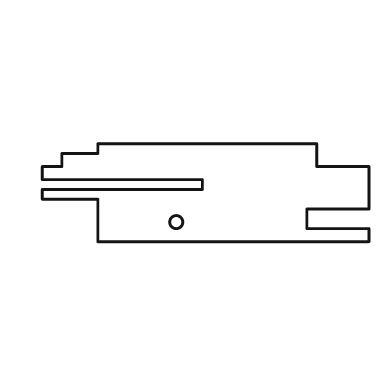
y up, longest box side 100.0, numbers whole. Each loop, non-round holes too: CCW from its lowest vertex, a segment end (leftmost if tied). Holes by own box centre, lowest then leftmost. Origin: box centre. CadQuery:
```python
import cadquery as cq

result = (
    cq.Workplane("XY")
    .moveTo(-33.0, -15.0)
    .lineTo(50.0, -15.0)
    .lineTo(50.0, -11.0)
    .lineTo(31.0, -11.0)
    .lineTo(31.0, -5.0)
    .lineTo(50.0, -5.0)
    .lineTo(50.0, 8.0)
    .lineTo(34.0, 8.0)
    .lineTo(34.0, 15.0)
    .lineTo(-33.0, 15.0)
    .lineTo(-33.0, 12.0)
    .lineTo(-44.0, 12.0)
    .lineTo(-44.0, 8.0)
    .lineTo(-50.0, 8.0)
    .lineTo(-50.0, 4.0)
    .lineTo(-1.0, 4.0)
    .lineTo(-1.0, 1.0)
    .lineTo(-50.0, 1.0)
    .lineTo(-50.0, -2.0)
    .lineTo(-33.0, -2.0)
    .close()
    .moveTo(-9.0, -9.0)
    .circle(2.0)
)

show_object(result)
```